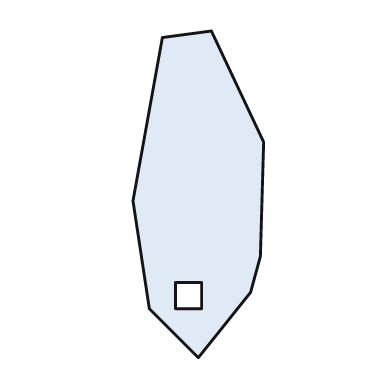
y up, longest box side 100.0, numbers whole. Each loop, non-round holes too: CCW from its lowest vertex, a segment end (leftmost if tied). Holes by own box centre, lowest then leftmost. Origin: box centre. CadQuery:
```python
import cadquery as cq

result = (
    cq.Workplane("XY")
    .moveTo(0.0, -50.0)
    .lineTo(16.0, -30.0)
    .lineTo(19.0, -19.0)
    .lineTo(20.0, 16.0)
    .lineTo(4.0, 50.0)
    .lineTo(-11.0, 48.0)
    .lineTo(-20.0, -2.0)
    .lineTo(-15.0, -35.0)
    .close()
    .moveTo(-7.0, -35.0)
    .lineTo(1.0, -35.0)
    .lineTo(1.0, -27.0)
    .lineTo(-7.0, -27.0)
    .close()
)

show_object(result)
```